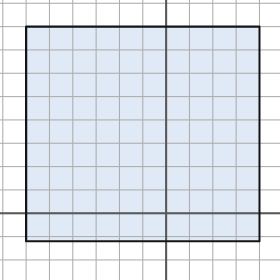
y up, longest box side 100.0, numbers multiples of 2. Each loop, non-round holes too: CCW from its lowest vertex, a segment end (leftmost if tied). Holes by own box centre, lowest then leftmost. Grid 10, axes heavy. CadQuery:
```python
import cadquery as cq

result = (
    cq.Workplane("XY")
    .moveTo(-60.0, -12.0)
    .lineTo(40.0, -12.0)
    .lineTo(40.0, 80.0)
    .lineTo(-60.0, 80.0)
    .close()
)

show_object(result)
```